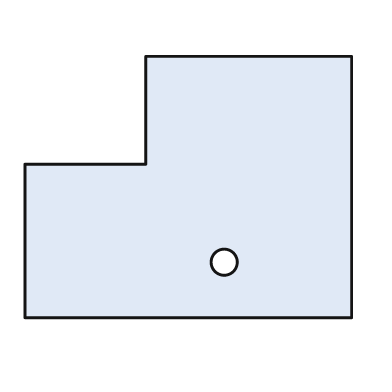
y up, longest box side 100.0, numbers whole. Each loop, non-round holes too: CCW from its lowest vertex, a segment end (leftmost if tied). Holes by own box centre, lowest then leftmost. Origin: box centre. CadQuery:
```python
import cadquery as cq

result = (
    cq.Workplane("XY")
    .moveTo(-50.0, -40.0)
    .lineTo(50.0, -40.0)
    .lineTo(50.0, 40.0)
    .lineTo(-13.0, 40.0)
    .lineTo(-13.0, 7.0)
    .lineTo(-50.0, 7.0)
    .close()
    .moveTo(11.0, -23.0)
    .circle(4.0)
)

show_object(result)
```